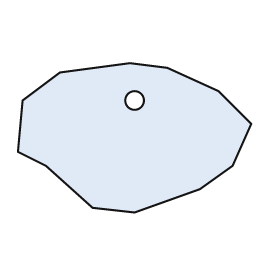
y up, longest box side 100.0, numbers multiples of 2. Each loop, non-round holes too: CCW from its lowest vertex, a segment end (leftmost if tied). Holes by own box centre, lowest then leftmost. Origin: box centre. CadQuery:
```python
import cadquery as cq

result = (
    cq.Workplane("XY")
    .moveTo(0.0, -32.0)
    .lineTo(28.0, -22.0)
    .lineTo(42.0, -12.0)
    .lineTo(50.0, 6.0)
    .lineTo(36.0, 20.0)
    .lineTo(14.0, 30.0)
    .lineTo(-2.0, 32.0)
    .lineTo(-32.0, 28.0)
    .lineTo(-48.0, 16.0)
    .lineTo(-50.0, -6.0)
    .lineTo(-38.0, -12.0)
    .lineTo(-18.0, -30.0)
    .close()
    .moveTo(0.0, 16.0)
    .circle(4.0)
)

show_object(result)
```